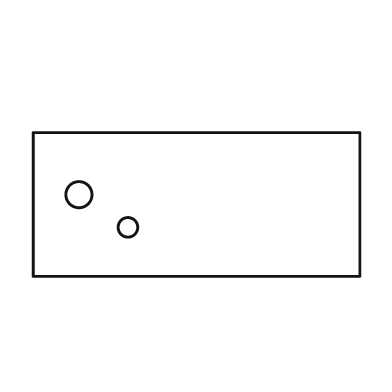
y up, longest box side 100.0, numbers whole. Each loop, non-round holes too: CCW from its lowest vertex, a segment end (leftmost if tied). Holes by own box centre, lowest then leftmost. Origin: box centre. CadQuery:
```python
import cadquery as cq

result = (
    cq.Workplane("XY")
    .moveTo(-50.0, -22.0)
    .lineTo(50.0, -22.0)
    .lineTo(50.0, 22.0)
    .lineTo(-50.0, 22.0)
    .close()
    .moveTo(-21.0, -7.0)
    .circle(3.0)
    .moveTo(-36.0, 3.0)
    .circle(4.0)
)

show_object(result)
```